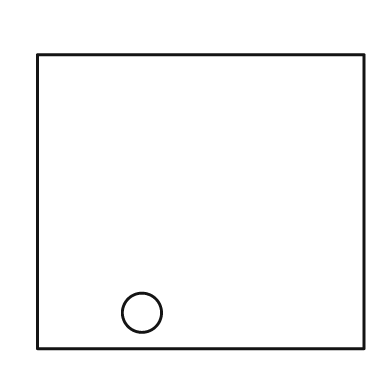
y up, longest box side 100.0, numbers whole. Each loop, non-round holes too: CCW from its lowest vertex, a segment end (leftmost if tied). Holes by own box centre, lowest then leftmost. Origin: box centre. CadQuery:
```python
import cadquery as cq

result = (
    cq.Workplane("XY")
    .moveTo(-50.0, -45.0)
    .lineTo(50.0, -45.0)
    .lineTo(50.0, 45.0)
    .lineTo(-50.0, 45.0)
    .close()
    .moveTo(-18.0, -34.0)
    .circle(6.0)
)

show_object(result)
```